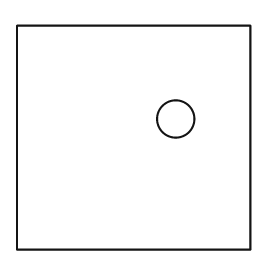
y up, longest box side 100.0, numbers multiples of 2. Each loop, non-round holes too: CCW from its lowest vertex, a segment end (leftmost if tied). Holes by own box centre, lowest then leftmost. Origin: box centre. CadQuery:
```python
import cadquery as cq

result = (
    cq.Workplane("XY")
    .moveTo(-50.0, -48.0)
    .lineTo(50.0, -48.0)
    .lineTo(50.0, 48.0)
    .lineTo(-50.0, 48.0)
    .close()
    .moveTo(18.0, 8.0)
    .circle(8.0)
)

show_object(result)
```